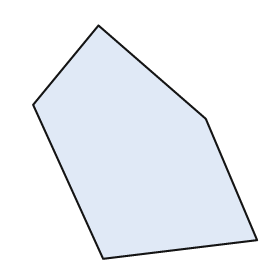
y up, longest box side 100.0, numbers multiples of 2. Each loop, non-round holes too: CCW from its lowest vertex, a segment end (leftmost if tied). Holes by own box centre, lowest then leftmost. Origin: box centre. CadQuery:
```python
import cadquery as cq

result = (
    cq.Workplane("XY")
    .moveTo(-18.0, -50.0)
    .lineTo(48.0, -42.0)
    .lineTo(26.0, 10.0)
    .lineTo(-20.0, 50.0)
    .lineTo(-48.0, 16.0)
    .close()
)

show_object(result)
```